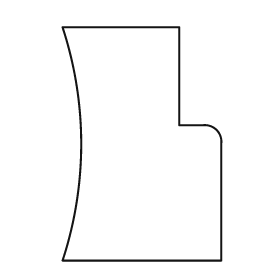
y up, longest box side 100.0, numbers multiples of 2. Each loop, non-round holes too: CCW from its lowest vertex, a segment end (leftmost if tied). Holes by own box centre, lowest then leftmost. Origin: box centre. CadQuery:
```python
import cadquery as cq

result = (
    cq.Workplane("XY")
    .moveTo(-34.0, -50.0)
    .lineTo(34.0, -50.0)
    .lineTo(34.0, 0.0)
    .threePointArc((32.0, 6.0), (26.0, 8.0))
    .lineTo(16.0, 8.0)
    .lineTo(16.0, 50.0)
    .lineTo(-34.0, 50.0)
    .threePointArc((-26.0, 0.0), (-34.0, -50.0))
    .close()
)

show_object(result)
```